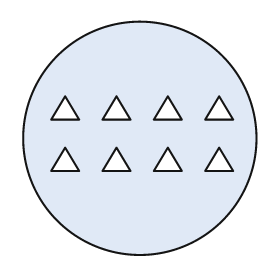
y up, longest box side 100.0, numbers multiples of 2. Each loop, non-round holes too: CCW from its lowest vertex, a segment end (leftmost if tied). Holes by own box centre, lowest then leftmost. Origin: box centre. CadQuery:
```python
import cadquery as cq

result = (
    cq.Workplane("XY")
    .moveTo(0.0, 0.0)
    .circle(50.0)
    .moveTo(-38.0, -14.0)
    .lineTo(-26.0, -14.0)
    .lineTo(-32.0, -4.0)
    .close()
    .moveTo(-16.0, -14.0)
    .lineTo(-4.0, -14.0)
    .lineTo(-10.0, -4.0)
    .close()
    .moveTo(6.0, -14.0)
    .lineTo(18.0, -14.0)
    .lineTo(12.0, -4.0)
    .close()
    .moveTo(28.0, -14.0)
    .lineTo(40.0, -14.0)
    .lineTo(34.0, -4.0)
    .close()
    .moveTo(-38.0, 8.0)
    .lineTo(-26.0, 8.0)
    .lineTo(-32.0, 18.0)
    .close()
    .moveTo(-16.0, 8.0)
    .lineTo(-4.0, 8.0)
    .lineTo(-10.0, 18.0)
    .close()
    .moveTo(6.0, 8.0)
    .lineTo(18.0, 8.0)
    .lineTo(12.0, 18.0)
    .close()
    .moveTo(28.0, 8.0)
    .lineTo(40.0, 8.0)
    .lineTo(34.0, 18.0)
    .close()
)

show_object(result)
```